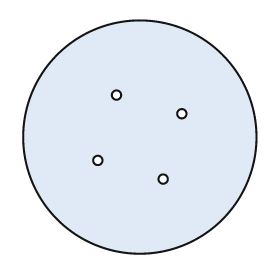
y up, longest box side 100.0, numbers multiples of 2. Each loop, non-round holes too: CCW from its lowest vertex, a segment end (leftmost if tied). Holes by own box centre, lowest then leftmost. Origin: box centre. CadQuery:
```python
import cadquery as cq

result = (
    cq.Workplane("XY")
    .moveTo(0.0, 0.0)
    .circle(50.0)
    .moveTo(10.0, -18.0)
    .circle(2.0)
    .moveTo(-18.0, -10.0)
    .circle(2.0)
    .moveTo(18.0, 10.0)
    .circle(2.0)
    .moveTo(-10.0, 18.0)
    .circle(2.0)
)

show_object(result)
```